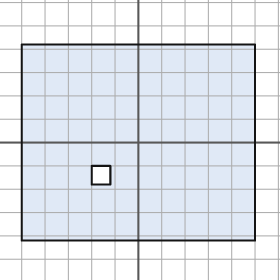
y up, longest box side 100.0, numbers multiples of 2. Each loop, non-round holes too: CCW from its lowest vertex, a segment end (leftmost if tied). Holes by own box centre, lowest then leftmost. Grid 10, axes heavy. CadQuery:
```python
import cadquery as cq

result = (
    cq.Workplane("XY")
    .moveTo(-50.0, -42.0)
    .lineTo(50.0, -42.0)
    .lineTo(50.0, 42.0)
    .lineTo(-50.0, 42.0)
    .close()
    .moveTo(-20.0, -18.0)
    .lineTo(-12.0, -18.0)
    .lineTo(-12.0, -10.0)
    .lineTo(-20.0, -10.0)
    .close()
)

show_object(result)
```